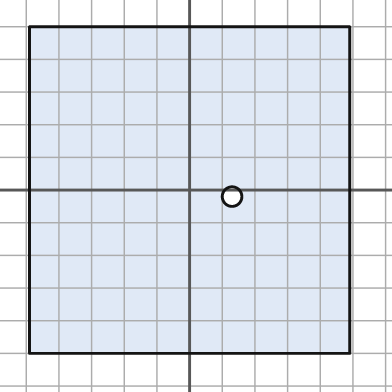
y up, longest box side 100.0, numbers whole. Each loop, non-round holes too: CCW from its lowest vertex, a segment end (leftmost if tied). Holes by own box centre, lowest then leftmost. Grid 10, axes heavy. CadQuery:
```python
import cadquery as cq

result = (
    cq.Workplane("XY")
    .moveTo(-49.0, -50.0)
    .lineTo(49.0, -50.0)
    .lineTo(49.0, 50.0)
    .lineTo(-49.0, 50.0)
    .close()
    .moveTo(13.0, -2.0)
    .circle(3.0)
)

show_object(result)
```